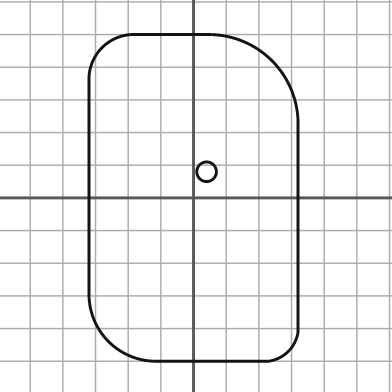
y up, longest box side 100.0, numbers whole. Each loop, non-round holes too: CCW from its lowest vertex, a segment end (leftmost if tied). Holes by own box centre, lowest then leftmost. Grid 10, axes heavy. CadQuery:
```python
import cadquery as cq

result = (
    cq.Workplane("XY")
    .moveTo(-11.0, -50.0)
    .lineTo(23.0, -50.0)
    .threePointArc((29.0, -47.0), (32.0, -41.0))
    .lineTo(32.0, 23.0)
    .threePointArc((24.0, 42.0), (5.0, 50.0))
    .lineTo(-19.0, 50.0)
    .threePointArc((-28.0, 46.0), (-32.0, 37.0))
    .lineTo(-32.0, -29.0)
    .threePointArc((-26.0, -44.0), (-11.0, -50.0))
    .close()
    .moveTo(4.0, 8.0)
    .circle(3.0)
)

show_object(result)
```